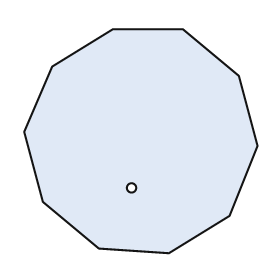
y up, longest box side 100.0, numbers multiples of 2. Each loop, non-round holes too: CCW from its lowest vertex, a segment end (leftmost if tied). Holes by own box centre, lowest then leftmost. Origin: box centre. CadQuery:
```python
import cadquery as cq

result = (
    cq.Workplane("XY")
    .moveTo(12.0, -48.0)
    .lineTo(38.0, -32.0)
    .lineTo(50.0, -2.0)
    .lineTo(42.0, 28.0)
    .lineTo(18.0, 48.0)
    .lineTo(-12.0, 48.0)
    .lineTo(-38.0, 32.0)
    .lineTo(-50.0, 4.0)
    .lineTo(-42.0, -26.0)
    .lineTo(-18.0, -46.0)
    .close()
    .moveTo(-4.0, -20.0)
    .circle(2.0)
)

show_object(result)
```